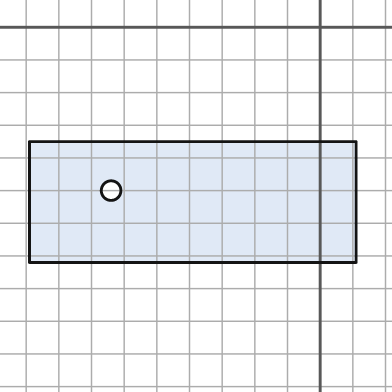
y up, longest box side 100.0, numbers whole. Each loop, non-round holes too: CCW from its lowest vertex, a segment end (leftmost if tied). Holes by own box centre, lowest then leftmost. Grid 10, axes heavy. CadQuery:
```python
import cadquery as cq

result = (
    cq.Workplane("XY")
    .moveTo(-89.0, -72.0)
    .lineTo(11.0, -72.0)
    .lineTo(11.0, -35.0)
    .lineTo(-89.0, -35.0)
    .close()
    .moveTo(-64.0, -50.0)
    .circle(3.0)
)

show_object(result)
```